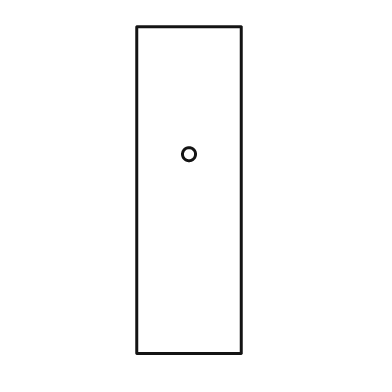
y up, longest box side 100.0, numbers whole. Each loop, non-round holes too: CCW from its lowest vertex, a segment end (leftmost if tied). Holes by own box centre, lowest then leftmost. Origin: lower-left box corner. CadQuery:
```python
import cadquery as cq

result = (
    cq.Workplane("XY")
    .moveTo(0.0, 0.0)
    .lineTo(32.0, 0.0)
    .lineTo(32.0, 100.0)
    .lineTo(0.0, 100.0)
    .close()
    .moveTo(16.0, 61.0)
    .circle(2.0)
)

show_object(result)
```